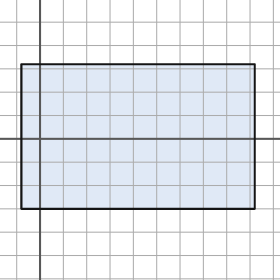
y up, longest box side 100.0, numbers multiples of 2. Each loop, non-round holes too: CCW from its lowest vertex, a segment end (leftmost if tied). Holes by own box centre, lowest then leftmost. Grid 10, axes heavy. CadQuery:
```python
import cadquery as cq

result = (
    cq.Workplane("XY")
    .moveTo(-8.0, -30.0)
    .lineTo(92.0, -30.0)
    .lineTo(92.0, 32.0)
    .lineTo(-8.0, 32.0)
    .close()
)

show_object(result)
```